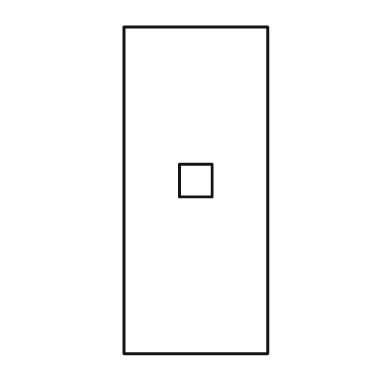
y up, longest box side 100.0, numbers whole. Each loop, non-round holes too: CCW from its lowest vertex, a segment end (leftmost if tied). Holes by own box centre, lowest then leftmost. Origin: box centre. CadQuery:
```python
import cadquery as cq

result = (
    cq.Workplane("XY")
    .moveTo(-22.0, -50.0)
    .lineTo(22.0, -50.0)
    .lineTo(22.0, 50.0)
    .lineTo(-22.0, 50.0)
    .close()
    .moveTo(-5.0, -2.0)
    .lineTo(5.0, -2.0)
    .lineTo(5.0, 8.0)
    .lineTo(-5.0, 8.0)
    .close()
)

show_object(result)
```